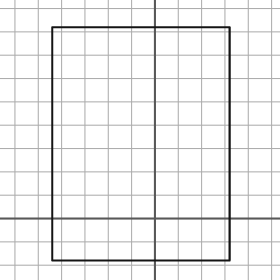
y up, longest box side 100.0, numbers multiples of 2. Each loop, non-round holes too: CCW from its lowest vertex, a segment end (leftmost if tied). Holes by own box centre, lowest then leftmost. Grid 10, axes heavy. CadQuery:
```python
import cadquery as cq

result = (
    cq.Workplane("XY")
    .moveTo(-44.0, -18.0)
    .lineTo(32.0, -18.0)
    .lineTo(32.0, 82.0)
    .lineTo(-44.0, 82.0)
    .close()
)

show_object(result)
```